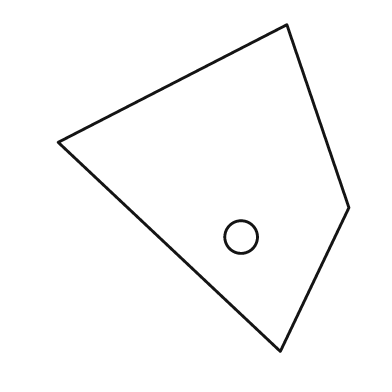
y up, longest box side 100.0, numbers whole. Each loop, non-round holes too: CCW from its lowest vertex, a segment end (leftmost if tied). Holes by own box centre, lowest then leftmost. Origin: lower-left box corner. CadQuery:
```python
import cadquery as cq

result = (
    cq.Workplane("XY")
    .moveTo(68.0, 0.0)
    .lineTo(89.0, 44.0)
    .lineTo(70.0, 100.0)
    .lineTo(0.0, 64.0)
    .close()
    .moveTo(56.0, 35.0)
    .circle(5.0)
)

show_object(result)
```